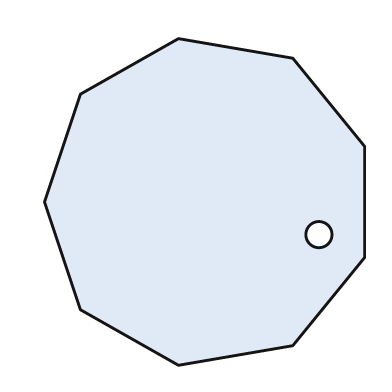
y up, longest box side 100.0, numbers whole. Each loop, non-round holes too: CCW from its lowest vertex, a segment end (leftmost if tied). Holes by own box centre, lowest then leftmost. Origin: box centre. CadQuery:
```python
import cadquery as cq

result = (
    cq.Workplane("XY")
    .moveTo(-8.0, -50.0)
    .lineTo(27.0, -44.0)
    .lineTo(49.0, -17.0)
    .lineTo(49.0, 17.0)
    .lineTo(27.0, 44.0)
    .lineTo(-8.0, 50.0)
    .lineTo(-38.0, 33.0)
    .lineTo(-49.0, 0.0)
    .lineTo(-38.0, -33.0)
    .close()
    .moveTo(35.0, -10.0)
    .circle(4.0)
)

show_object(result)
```